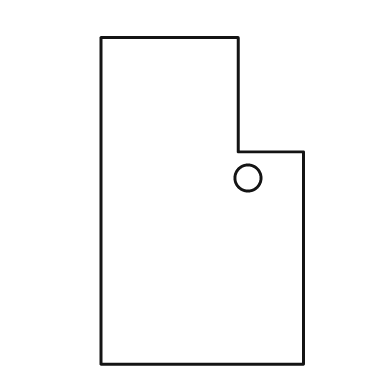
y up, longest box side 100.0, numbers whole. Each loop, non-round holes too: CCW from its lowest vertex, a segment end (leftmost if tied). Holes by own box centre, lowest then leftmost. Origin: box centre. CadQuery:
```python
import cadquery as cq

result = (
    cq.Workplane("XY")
    .moveTo(-31.0, -50.0)
    .lineTo(31.0, -50.0)
    .lineTo(31.0, 15.0)
    .lineTo(11.0, 15.0)
    .lineTo(11.0, 50.0)
    .lineTo(-31.0, 50.0)
    .close()
    .moveTo(14.0, 7.0)
    .circle(4.0)
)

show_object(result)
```